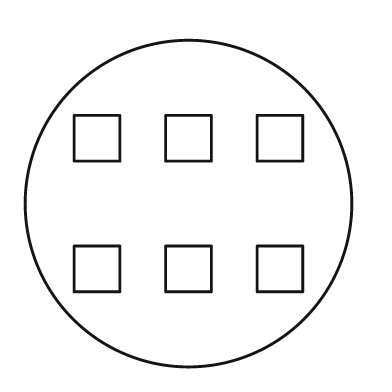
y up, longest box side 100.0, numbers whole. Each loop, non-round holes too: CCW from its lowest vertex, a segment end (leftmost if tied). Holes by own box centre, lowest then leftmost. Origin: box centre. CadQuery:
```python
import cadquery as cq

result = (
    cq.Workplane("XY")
    .moveTo(0.0, 0.0)
    .circle(50.0)
    .moveTo(-35.0, -27.0)
    .lineTo(-21.0, -27.0)
    .lineTo(-21.0, -13.0)
    .lineTo(-35.0, -13.0)
    .close()
    .moveTo(-7.0, -27.0)
    .lineTo(7.0, -27.0)
    .lineTo(7.0, -13.0)
    .lineTo(-7.0, -13.0)
    .close()
    .moveTo(21.0, -27.0)
    .lineTo(35.0, -27.0)
    .lineTo(35.0, -13.0)
    .lineTo(21.0, -13.0)
    .close()
    .moveTo(-35.0, 13.0)
    .lineTo(-21.0, 13.0)
    .lineTo(-21.0, 27.0)
    .lineTo(-35.0, 27.0)
    .close()
    .moveTo(-7.0, 13.0)
    .lineTo(7.0, 13.0)
    .lineTo(7.0, 27.0)
    .lineTo(-7.0, 27.0)
    .close()
    .moveTo(21.0, 13.0)
    .lineTo(35.0, 13.0)
    .lineTo(35.0, 27.0)
    .lineTo(21.0, 27.0)
    .close()
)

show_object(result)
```